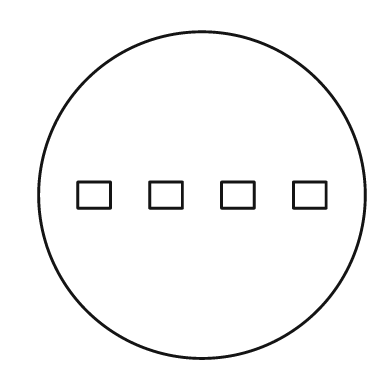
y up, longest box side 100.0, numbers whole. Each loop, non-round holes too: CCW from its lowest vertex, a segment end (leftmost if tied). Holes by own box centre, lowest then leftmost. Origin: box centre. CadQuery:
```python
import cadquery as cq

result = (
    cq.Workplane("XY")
    .moveTo(0.0, 0.0)
    .circle(50.0)
    .moveTo(-38.0, -4.0)
    .lineTo(-28.0, -4.0)
    .lineTo(-28.0, 4.0)
    .lineTo(-38.0, 4.0)
    .close()
    .moveTo(-16.0, -4.0)
    .lineTo(-6.0, -4.0)
    .lineTo(-6.0, 4.0)
    .lineTo(-16.0, 4.0)
    .close()
    .moveTo(6.0, -4.0)
    .lineTo(16.0, -4.0)
    .lineTo(16.0, 4.0)
    .lineTo(6.0, 4.0)
    .close()
    .moveTo(28.0, -4.0)
    .lineTo(38.0, -4.0)
    .lineTo(38.0, 4.0)
    .lineTo(28.0, 4.0)
    .close()
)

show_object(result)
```